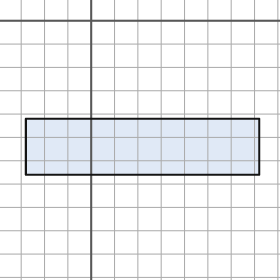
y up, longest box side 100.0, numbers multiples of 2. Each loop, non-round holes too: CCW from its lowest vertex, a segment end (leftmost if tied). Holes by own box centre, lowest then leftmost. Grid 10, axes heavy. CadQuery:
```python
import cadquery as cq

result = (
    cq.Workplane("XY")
    .moveTo(-28.0, -66.0)
    .lineTo(72.0, -66.0)
    .lineTo(72.0, -42.0)
    .lineTo(-28.0, -42.0)
    .close()
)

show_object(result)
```